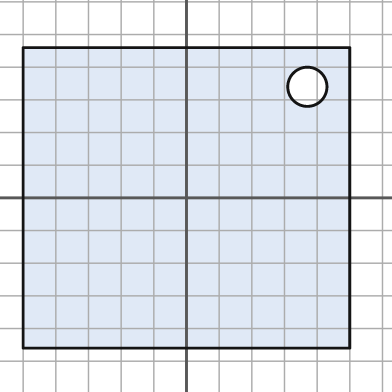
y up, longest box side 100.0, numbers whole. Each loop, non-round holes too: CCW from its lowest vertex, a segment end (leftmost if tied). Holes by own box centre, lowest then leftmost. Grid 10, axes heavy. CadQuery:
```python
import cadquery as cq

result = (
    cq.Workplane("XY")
    .moveTo(-50.0, -46.0)
    .lineTo(50.0, -46.0)
    .lineTo(50.0, 46.0)
    .lineTo(-50.0, 46.0)
    .close()
    .moveTo(37.0, 34.0)
    .circle(6.0)
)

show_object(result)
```